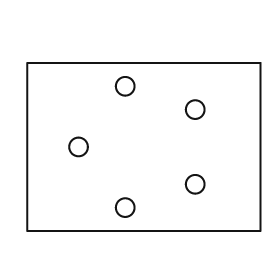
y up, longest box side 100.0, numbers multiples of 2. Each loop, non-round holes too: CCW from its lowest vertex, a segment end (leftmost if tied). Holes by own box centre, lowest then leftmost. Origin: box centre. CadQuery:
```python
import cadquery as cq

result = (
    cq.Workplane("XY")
    .moveTo(-50.0, -36.0)
    .lineTo(50.0, -36.0)
    .lineTo(50.0, 36.0)
    .lineTo(-50.0, 36.0)
    .close()
    .moveTo(-8.0, -26.0)
    .circle(4.0)
    .moveTo(22.0, -16.0)
    .circle(4.0)
    .moveTo(-28.0, 0.0)
    .circle(4.0)
    .moveTo(22.0, 16.0)
    .circle(4.0)
    .moveTo(-8.0, 26.0)
    .circle(4.0)
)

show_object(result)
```